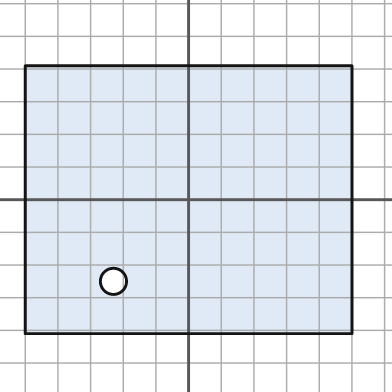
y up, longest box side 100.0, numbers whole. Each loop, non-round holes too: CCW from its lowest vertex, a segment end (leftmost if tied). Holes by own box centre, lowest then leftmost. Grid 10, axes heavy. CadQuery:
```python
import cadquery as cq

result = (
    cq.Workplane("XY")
    .moveTo(-50.0, -41.0)
    .lineTo(50.0, -41.0)
    .lineTo(50.0, 41.0)
    .lineTo(-50.0, 41.0)
    .close()
    .moveTo(-23.0, -25.0)
    .circle(4.0)
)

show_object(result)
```